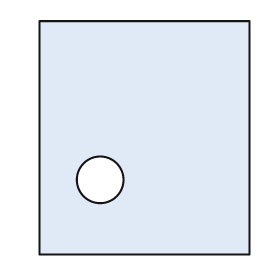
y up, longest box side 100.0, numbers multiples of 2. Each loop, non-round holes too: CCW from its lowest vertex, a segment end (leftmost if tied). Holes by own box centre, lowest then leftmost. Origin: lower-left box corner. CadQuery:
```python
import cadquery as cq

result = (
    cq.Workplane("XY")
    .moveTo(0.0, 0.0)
    .lineTo(90.0, 0.0)
    .lineTo(90.0, 100.0)
    .lineTo(0.0, 100.0)
    .close()
    .moveTo(26.0, 32.0)
    .circle(10.0)
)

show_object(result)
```